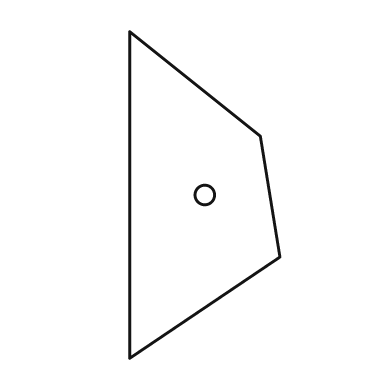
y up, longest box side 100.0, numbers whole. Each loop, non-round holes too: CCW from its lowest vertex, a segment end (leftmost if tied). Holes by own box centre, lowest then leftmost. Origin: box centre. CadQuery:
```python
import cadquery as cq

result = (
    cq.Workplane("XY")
    .moveTo(-23.0, -50.0)
    .lineTo(23.0, -19.0)
    .lineTo(17.0, 18.0)
    .lineTo(-23.0, 50.0)
    .close()
    .moveTo(0.0, 0.0)
    .circle(3.0)
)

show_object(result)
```